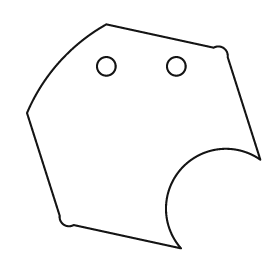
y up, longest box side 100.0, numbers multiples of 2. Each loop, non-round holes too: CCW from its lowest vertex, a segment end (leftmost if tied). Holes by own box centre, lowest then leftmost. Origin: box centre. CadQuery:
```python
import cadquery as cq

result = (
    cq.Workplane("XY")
    .moveTo(16.0, -48.0)
    .threePointArc((16.0, -14.0), (50.0, -10.0))
    .lineTo(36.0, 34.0)
    .threePointArc((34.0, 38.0), (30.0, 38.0))
    .lineTo(-16.0, 48.0)
    .threePointArc((-36.0, 32.0), (-50.0, 10.0))
    .lineTo(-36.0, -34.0)
    .threePointArc((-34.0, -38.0), (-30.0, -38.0))
    .close()
    .moveTo(-16.0, 30.0)
    .circle(4.0)
    .moveTo(14.0, 30.0)
    .circle(4.0)
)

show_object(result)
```